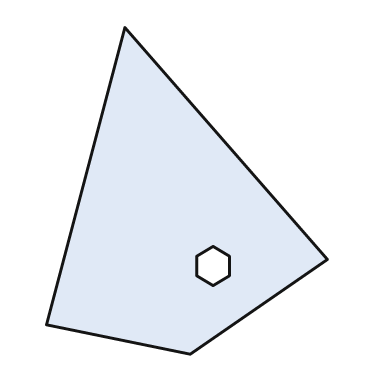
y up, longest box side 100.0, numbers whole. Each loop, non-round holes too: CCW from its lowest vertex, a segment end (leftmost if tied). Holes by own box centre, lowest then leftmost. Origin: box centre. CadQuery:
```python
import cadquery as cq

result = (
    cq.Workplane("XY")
    .moveTo(1.0, -50.0)
    .lineTo(43.0, -21.0)
    .lineTo(-19.0, 50.0)
    .lineTo(-43.0, -41.0)
    .close()
    .moveTo(8.0, -29.0)
    .lineTo(13.0, -26.0)
    .lineTo(13.0, -20.0)
    .lineTo(8.0, -17.0)
    .lineTo(3.0, -20.0)
    .lineTo(3.0, -26.0)
    .close()
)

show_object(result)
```